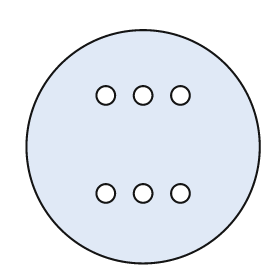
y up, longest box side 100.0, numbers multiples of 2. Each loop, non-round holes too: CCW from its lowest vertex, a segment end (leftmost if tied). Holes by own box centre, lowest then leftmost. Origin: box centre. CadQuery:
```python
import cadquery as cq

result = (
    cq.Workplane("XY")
    .moveTo(0.0, 0.0)
    .circle(50.0)
    .moveTo(-16.0, -20.0)
    .circle(4.0)
    .moveTo(0.0, -20.0)
    .circle(4.0)
    .moveTo(16.0, -20.0)
    .circle(4.0)
    .moveTo(-16.0, 22.0)
    .circle(4.0)
    .moveTo(0.0, 22.0)
    .circle(4.0)
    .moveTo(16.0, 22.0)
    .circle(4.0)
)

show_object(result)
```